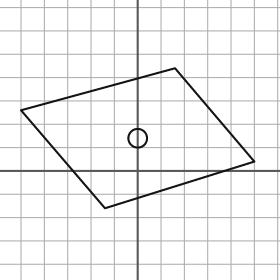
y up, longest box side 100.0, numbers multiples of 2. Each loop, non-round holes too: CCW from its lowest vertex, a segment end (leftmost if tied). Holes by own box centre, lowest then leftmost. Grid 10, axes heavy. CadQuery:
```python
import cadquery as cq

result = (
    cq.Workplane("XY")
    .moveTo(-14.0, -16.0)
    .lineTo(50.0, 4.0)
    .lineTo(16.0, 44.0)
    .lineTo(-50.0, 26.0)
    .close()
    .moveTo(0.0, 14.0)
    .circle(4.0)
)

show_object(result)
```